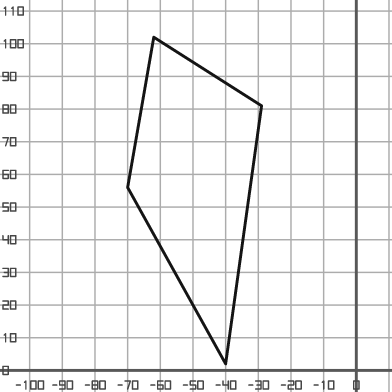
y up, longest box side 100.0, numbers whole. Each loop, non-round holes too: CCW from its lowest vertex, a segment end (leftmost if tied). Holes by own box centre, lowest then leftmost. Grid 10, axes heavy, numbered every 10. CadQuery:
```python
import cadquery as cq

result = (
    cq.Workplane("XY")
    .moveTo(-40.0, 2.0)
    .lineTo(-29.0, 81.0)
    .lineTo(-62.0, 102.0)
    .lineTo(-70.0, 56.0)
    .close()
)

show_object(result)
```